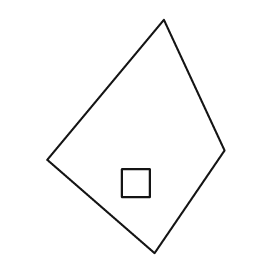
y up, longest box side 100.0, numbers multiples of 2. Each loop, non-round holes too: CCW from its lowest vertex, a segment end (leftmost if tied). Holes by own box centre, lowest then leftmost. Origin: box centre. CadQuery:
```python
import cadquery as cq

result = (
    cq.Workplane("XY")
    .moveTo(8.0, -50.0)
    .lineTo(38.0, -6.0)
    .lineTo(12.0, 50.0)
    .lineTo(-38.0, -10.0)
    .close()
    .moveTo(-6.0, -26.0)
    .lineTo(6.0, -26.0)
    .lineTo(6.0, -14.0)
    .lineTo(-6.0, -14.0)
    .close()
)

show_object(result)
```